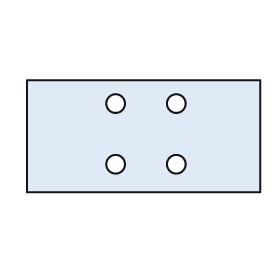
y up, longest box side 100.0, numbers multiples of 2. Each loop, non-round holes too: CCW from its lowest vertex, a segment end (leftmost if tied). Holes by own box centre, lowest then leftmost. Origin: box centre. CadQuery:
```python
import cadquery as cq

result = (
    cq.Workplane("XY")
    .moveTo(-50.0, -24.0)
    .lineTo(50.0, -24.0)
    .lineTo(50.0, 24.0)
    .lineTo(-50.0, 24.0)
    .close()
    .moveTo(-12.0, -12.0)
    .circle(4.0)
    .moveTo(14.0, -12.0)
    .circle(4.0)
    .moveTo(-12.0, 14.0)
    .circle(4.0)
    .moveTo(14.0, 14.0)
    .circle(4.0)
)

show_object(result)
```